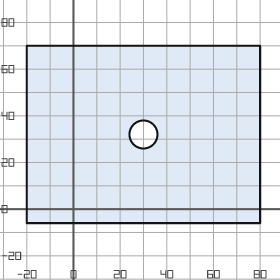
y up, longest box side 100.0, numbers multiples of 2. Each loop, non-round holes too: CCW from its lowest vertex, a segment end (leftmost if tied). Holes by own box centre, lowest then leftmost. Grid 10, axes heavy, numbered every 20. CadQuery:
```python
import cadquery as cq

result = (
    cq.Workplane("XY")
    .moveTo(-20.0, -6.0)
    .lineTo(80.0, -6.0)
    .lineTo(80.0, 70.0)
    .lineTo(-20.0, 70.0)
    .close()
    .moveTo(30.0, 32.0)
    .circle(6.0)
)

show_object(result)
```